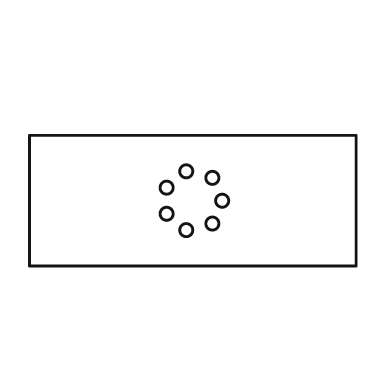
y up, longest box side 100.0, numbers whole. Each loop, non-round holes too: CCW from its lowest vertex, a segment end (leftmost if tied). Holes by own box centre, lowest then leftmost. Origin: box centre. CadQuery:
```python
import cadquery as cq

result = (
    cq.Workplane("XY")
    .moveTo(-50.0, -20.0)
    .lineTo(50.0, -20.0)
    .lineTo(50.0, 20.0)
    .lineTo(-50.0, 20.0)
    .close()
    .moveTo(-2.0, -9.0)
    .circle(2.0)
    .moveTo(6.0, -7.0)
    .circle(2.0)
    .moveTo(-8.0, -4.0)
    .circle(2.0)
    .moveTo(9.0, 0.0)
    .circle(2.0)
    .moveTo(-8.0, 4.0)
    .circle(2.0)
    .moveTo(6.0, 7.0)
    .circle(2.0)
    .moveTo(-2.0, 9.0)
    .circle(2.0)
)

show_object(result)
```